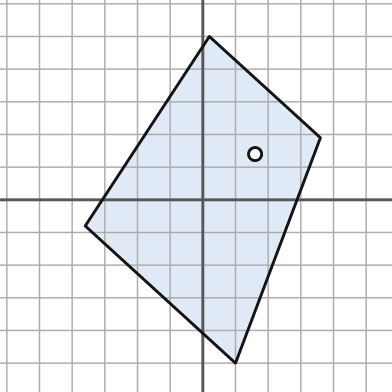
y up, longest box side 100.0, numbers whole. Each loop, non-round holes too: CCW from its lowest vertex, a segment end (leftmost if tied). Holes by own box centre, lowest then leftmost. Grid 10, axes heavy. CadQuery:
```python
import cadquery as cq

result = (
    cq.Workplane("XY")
    .moveTo(10.0, -50.0)
    .lineTo(36.0, 19.0)
    .lineTo(2.0, 50.0)
    .lineTo(-36.0, -8.0)
    .close()
    .moveTo(16.0, 14.0)
    .circle(2.0)
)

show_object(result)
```